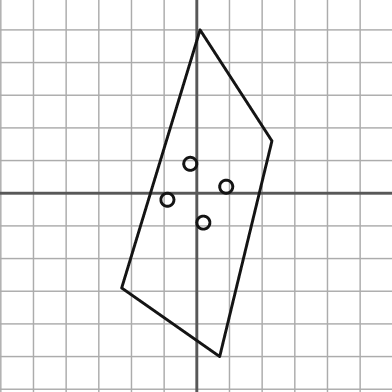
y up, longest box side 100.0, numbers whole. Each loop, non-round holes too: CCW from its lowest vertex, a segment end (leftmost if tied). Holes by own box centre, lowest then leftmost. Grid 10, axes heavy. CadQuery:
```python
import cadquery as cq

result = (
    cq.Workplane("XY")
    .moveTo(7.0, -50.0)
    .lineTo(23.0, 16.0)
    .lineTo(1.0, 50.0)
    .lineTo(-23.0, -29.0)
    .close()
    .moveTo(2.0, -9.0)
    .circle(2.0)
    .moveTo(-9.0, -2.0)
    .circle(2.0)
    .moveTo(9.0, 2.0)
    .circle(2.0)
    .moveTo(-2.0, 9.0)
    .circle(2.0)
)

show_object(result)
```